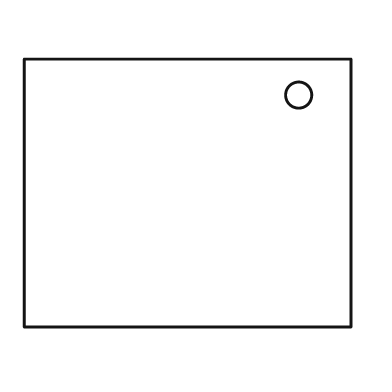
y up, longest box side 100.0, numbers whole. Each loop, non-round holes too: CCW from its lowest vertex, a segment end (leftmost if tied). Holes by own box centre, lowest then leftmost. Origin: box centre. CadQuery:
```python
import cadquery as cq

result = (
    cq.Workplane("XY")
    .moveTo(-50.0, -41.0)
    .lineTo(50.0, -41.0)
    .lineTo(50.0, 41.0)
    .lineTo(-50.0, 41.0)
    .close()
    .moveTo(34.0, 30.0)
    .circle(4.0)
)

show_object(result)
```